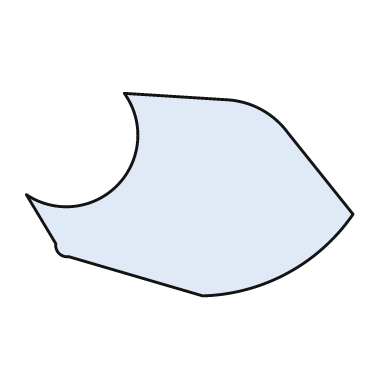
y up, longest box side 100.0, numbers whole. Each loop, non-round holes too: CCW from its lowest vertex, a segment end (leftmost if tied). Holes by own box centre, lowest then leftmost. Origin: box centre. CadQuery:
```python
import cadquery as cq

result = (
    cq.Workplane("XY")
    .moveTo(4.0, -31.0)
    .threePointArc((30.0, -24.0), (50.0, -6.0))
    .lineTo(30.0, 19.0)
    .threePointArc((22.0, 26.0), (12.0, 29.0))
    .lineTo(-20.0, 31.0)
    .threePointArc((-22.0, 3.0), (-50.0, 0.0))
    .lineTo(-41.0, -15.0)
    .threePointArc((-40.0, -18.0), (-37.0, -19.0))
    .close()
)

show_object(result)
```